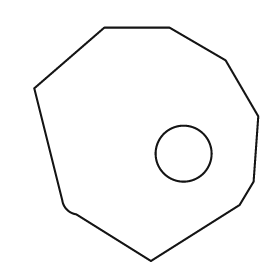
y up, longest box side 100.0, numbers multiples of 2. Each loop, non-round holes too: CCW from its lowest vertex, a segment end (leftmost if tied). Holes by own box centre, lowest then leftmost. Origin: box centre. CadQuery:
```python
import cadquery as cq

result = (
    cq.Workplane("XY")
    .moveTo(2.0, -50.0)
    .lineTo(40.0, -26.0)
    .lineTo(46.0, -16.0)
    .lineTo(48.0, 12.0)
    .lineTo(34.0, 36.0)
    .lineTo(10.0, 50.0)
    .lineTo(-18.0, 50.0)
    .lineTo(-48.0, 24.0)
    .lineTo(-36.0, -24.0)
    .threePointArc((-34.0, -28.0), (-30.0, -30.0))
    .close()
    .moveTo(16.0, -4.0)
    .circle(12.0)
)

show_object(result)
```